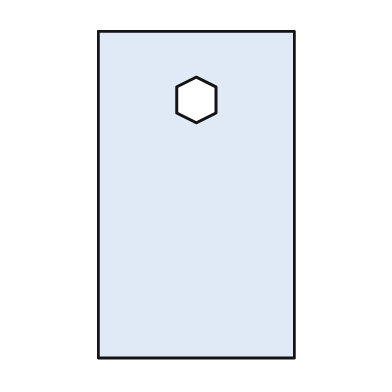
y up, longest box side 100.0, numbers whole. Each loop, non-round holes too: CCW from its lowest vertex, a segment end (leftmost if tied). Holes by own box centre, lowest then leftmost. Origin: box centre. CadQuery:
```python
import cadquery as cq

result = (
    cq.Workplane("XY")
    .moveTo(-30.0, -50.0)
    .lineTo(30.0, -50.0)
    .lineTo(30.0, 50.0)
    .lineTo(-30.0, 50.0)
    .close()
    .moveTo(0.0, 22.0)
    .lineTo(6.0, 25.0)
    .lineTo(6.0, 33.0)
    .lineTo(0.0, 36.0)
    .lineTo(-6.0, 33.0)
    .lineTo(-6.0, 25.0)
    .close()
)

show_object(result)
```